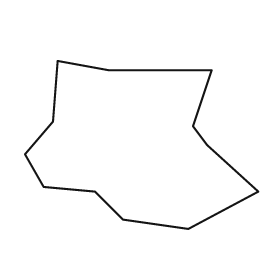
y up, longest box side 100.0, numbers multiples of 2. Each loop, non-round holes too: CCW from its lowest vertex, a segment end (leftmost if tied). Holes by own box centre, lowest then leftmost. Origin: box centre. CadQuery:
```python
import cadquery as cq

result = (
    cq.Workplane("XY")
    .moveTo(20.0, -36.0)
    .lineTo(50.0, -20.0)
    .lineTo(28.0, 0.0)
    .lineTo(22.0, 8.0)
    .lineTo(30.0, 32.0)
    .lineTo(-14.0, 32.0)
    .lineTo(-36.0, 36.0)
    .lineTo(-38.0, 10.0)
    .lineTo(-50.0, -4.0)
    .lineTo(-42.0, -18.0)
    .lineTo(-20.0, -20.0)
    .lineTo(-8.0, -32.0)
    .close()
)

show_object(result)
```